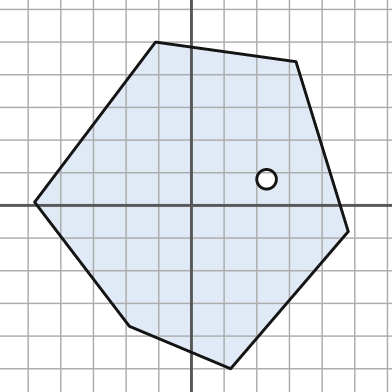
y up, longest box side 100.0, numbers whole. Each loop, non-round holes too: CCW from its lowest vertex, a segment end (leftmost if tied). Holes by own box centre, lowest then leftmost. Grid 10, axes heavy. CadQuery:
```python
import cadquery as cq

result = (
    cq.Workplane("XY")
    .moveTo(12.0, -50.0)
    .lineTo(48.0, -8.0)
    .lineTo(32.0, 44.0)
    .lineTo(-11.0, 50.0)
    .lineTo(-48.0, 1.0)
    .lineTo(-19.0, -37.0)
    .close()
    .moveTo(23.0, 8.0)
    .circle(3.0)
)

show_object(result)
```